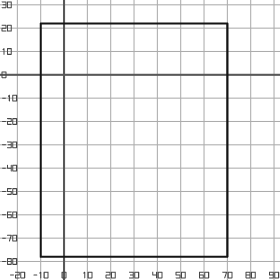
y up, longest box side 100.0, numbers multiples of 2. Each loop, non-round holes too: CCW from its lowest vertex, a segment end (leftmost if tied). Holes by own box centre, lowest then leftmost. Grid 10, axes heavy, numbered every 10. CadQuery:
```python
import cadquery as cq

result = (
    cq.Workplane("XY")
    .moveTo(-10.0, -78.0)
    .lineTo(70.0, -78.0)
    .lineTo(70.0, 22.0)
    .lineTo(-10.0, 22.0)
    .close()
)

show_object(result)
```